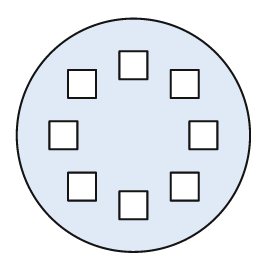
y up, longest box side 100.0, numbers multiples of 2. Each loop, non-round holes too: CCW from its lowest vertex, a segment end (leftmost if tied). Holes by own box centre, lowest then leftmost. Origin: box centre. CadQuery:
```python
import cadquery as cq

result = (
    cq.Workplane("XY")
    .moveTo(0.0, 0.0)
    .circle(50.0)
    .moveTo(-6.0, -36.0)
    .lineTo(6.0, -36.0)
    .lineTo(6.0, -24.0)
    .lineTo(-6.0, -24.0)
    .close()
    .moveTo(-28.0, -28.0)
    .lineTo(-16.0, -28.0)
    .lineTo(-16.0, -16.0)
    .lineTo(-28.0, -16.0)
    .close()
    .moveTo(16.0, -28.0)
    .lineTo(28.0, -28.0)
    .lineTo(28.0, -16.0)
    .lineTo(16.0, -16.0)
    .close()
    .moveTo(-36.0, -6.0)
    .lineTo(-24.0, -6.0)
    .lineTo(-24.0, 6.0)
    .lineTo(-36.0, 6.0)
    .close()
    .moveTo(24.0, -6.0)
    .lineTo(36.0, -6.0)
    .lineTo(36.0, 6.0)
    .lineTo(24.0, 6.0)
    .close()
    .moveTo(-28.0, 16.0)
    .lineTo(-16.0, 16.0)
    .lineTo(-16.0, 28.0)
    .lineTo(-28.0, 28.0)
    .close()
    .moveTo(16.0, 16.0)
    .lineTo(28.0, 16.0)
    .lineTo(28.0, 28.0)
    .lineTo(16.0, 28.0)
    .close()
    .moveTo(-6.0, 24.0)
    .lineTo(6.0, 24.0)
    .lineTo(6.0, 36.0)
    .lineTo(-6.0, 36.0)
    .close()
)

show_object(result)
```